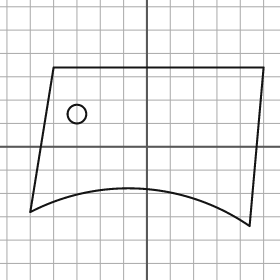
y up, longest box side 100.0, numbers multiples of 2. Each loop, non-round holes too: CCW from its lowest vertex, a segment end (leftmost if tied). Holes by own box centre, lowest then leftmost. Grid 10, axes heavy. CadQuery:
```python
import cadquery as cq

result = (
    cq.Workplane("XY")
    .moveTo(44.0, -34.0)
    .lineTo(50.0, 34.0)
    .lineTo(-40.0, 34.0)
    .lineTo(-50.0, -28.0)
    .threePointArc((-2.0, -18.0), (44.0, -34.0))
    .close()
    .moveTo(-30.0, 14.0)
    .circle(4.0)
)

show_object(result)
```